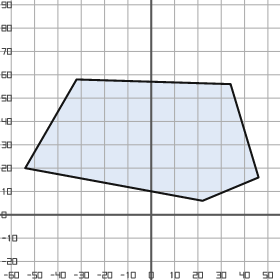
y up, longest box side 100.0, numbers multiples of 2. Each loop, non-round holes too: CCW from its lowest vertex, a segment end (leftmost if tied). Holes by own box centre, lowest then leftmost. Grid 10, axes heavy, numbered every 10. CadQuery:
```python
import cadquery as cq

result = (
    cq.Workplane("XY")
    .moveTo(22.0, 6.0)
    .lineTo(46.0, 16.0)
    .lineTo(34.0, 56.0)
    .lineTo(-32.0, 58.0)
    .lineTo(-54.0, 20.0)
    .close()
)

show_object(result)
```